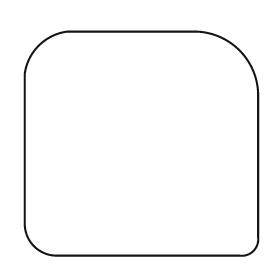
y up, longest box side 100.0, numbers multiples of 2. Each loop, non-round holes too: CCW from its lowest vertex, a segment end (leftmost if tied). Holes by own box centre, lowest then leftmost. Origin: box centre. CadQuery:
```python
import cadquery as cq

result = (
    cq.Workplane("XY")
    .moveTo(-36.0, -48.0)
    .lineTo(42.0, -48.0)
    .threePointArc((48.0, -46.0), (50.0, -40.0))
    .lineTo(50.0, 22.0)
    .threePointArc((42.0, 40.0), (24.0, 48.0))
    .lineTo(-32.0, 48.0)
    .threePointArc((-44.0, 42.0), (-50.0, 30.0))
    .lineTo(-50.0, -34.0)
    .threePointArc((-46.0, -44.0), (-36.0, -48.0))
    .close()
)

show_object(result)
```